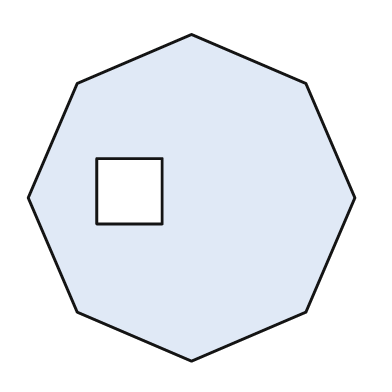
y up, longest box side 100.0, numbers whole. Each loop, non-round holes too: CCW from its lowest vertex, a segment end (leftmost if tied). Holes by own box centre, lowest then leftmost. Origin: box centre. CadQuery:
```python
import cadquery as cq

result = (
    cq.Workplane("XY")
    .moveTo(0.0, -50.0)
    .lineTo(35.0, -35.0)
    .lineTo(50.0, 0.0)
    .lineTo(35.0, 35.0)
    .lineTo(0.0, 50.0)
    .lineTo(-35.0, 35.0)
    .lineTo(-50.0, 0.0)
    .lineTo(-35.0, -35.0)
    .close()
    .moveTo(-29.0, -8.0)
    .lineTo(-9.0, -8.0)
    .lineTo(-9.0, 12.0)
    .lineTo(-29.0, 12.0)
    .close()
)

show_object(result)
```